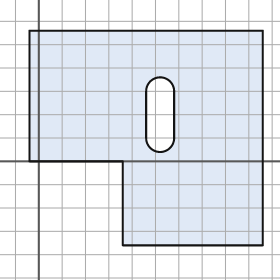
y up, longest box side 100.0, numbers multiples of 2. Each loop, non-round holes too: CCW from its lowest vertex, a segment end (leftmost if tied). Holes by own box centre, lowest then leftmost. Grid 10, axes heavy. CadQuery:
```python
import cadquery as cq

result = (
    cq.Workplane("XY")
    .moveTo(36.0, -36.0)
    .lineTo(96.0, -36.0)
    .lineTo(96.0, 56.0)
    .lineTo(-4.0, 56.0)
    .lineTo(-4.0, 0.0)
    .lineTo(36.0, 0.0)
    .close()
    .moveTo(46.0, 10.0)
    .threePointArc((52.0, 4.0), (58.0, 10.0))
    .lineTo(58.0, 30.0)
    .threePointArc((52.0, 36.0), (46.0, 30.0))
    .close()
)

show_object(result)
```